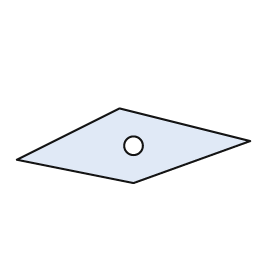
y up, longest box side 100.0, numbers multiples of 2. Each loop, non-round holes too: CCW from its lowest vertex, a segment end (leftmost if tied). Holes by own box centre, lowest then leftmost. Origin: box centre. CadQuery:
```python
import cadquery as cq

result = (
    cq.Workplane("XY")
    .moveTo(0.0, -16.0)
    .lineTo(50.0, 2.0)
    .lineTo(-6.0, 16.0)
    .lineTo(-50.0, -6.0)
    .close()
    .moveTo(0.0, 0.0)
    .circle(4.0)
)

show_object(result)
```